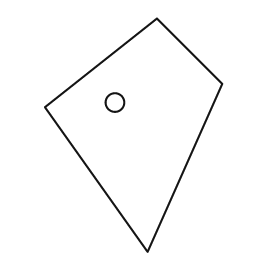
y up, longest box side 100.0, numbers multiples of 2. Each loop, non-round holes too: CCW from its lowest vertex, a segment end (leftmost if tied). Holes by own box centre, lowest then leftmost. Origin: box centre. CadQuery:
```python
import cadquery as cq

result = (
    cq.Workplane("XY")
    .moveTo(6.0, -50.0)
    .lineTo(38.0, 22.0)
    .lineTo(10.0, 50.0)
    .lineTo(-38.0, 12.0)
    .close()
    .moveTo(-8.0, 14.0)
    .circle(4.0)
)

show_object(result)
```